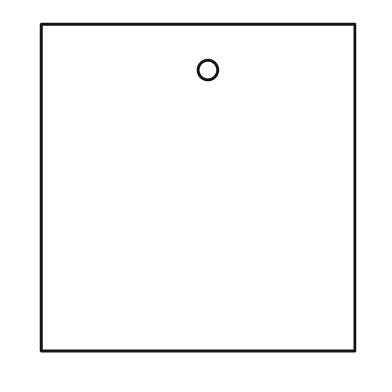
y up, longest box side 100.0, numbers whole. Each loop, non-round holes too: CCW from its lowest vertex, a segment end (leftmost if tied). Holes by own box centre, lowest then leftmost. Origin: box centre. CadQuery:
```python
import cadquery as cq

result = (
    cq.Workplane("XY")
    .moveTo(-48.0, -50.0)
    .lineTo(48.0, -50.0)
    .lineTo(48.0, 50.0)
    .lineTo(-48.0, 50.0)
    .close()
    .moveTo(3.0, 36.0)
    .circle(3.0)
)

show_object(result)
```